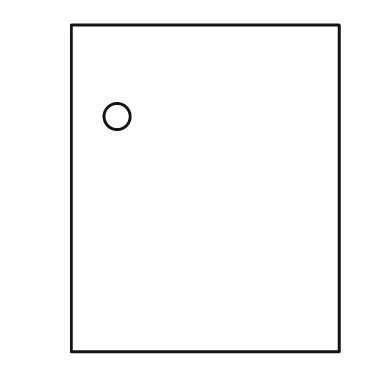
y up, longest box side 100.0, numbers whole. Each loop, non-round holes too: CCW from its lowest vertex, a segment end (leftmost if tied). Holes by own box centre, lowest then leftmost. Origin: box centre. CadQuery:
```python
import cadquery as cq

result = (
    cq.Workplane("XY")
    .moveTo(-41.0, -50.0)
    .lineTo(41.0, -50.0)
    .lineTo(41.0, 50.0)
    .lineTo(-41.0, 50.0)
    .close()
    .moveTo(-27.0, 22.0)
    .circle(4.0)
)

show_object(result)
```